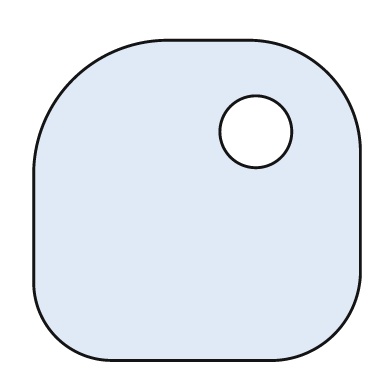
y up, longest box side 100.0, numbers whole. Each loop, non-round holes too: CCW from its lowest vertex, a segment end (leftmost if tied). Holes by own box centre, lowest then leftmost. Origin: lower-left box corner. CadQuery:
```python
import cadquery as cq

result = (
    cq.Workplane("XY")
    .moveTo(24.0, 0.0)
    .lineTo(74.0, 0.0)
    .threePointArc((92.0, 8.0), (100.0, 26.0))
    .lineTo(100.0, 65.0)
    .threePointArc((90.0, 88.0), (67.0, 98.0))
    .lineTo(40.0, 98.0)
    .threePointArc((12.0, 86.0), (0.0, 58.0))
    .lineTo(0.0, 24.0)
    .threePointArc((7.0, 7.0), (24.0, 0.0))
    .close()
    .moveTo(68.0, 70.0)
    .circle(11.0)
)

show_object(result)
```